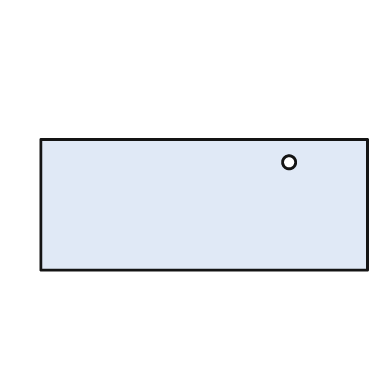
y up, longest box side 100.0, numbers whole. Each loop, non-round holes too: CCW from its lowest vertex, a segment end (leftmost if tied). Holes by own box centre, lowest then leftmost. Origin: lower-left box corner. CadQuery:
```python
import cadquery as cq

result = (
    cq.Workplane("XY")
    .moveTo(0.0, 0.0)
    .lineTo(100.0, 0.0)
    .lineTo(100.0, 40.0)
    .lineTo(0.0, 40.0)
    .close()
    .moveTo(76.0, 33.0)
    .circle(2.0)
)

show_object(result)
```